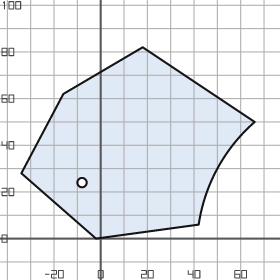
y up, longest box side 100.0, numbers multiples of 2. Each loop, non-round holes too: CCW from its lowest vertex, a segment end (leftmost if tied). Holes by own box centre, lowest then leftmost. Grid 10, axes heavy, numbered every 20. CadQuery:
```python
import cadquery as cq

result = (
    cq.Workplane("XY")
    .moveTo(-2.0, 0.0)
    .lineTo(42.0, 6.0)
    .threePointArc((50.0, 30.0), (66.0, 50.0))
    .lineTo(18.0, 82.0)
    .lineTo(-16.0, 62.0)
    .lineTo(-34.0, 28.0)
    .close()
    .moveTo(-8.0, 24.0)
    .circle(2.0)
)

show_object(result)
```